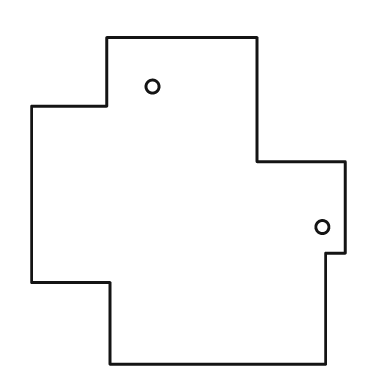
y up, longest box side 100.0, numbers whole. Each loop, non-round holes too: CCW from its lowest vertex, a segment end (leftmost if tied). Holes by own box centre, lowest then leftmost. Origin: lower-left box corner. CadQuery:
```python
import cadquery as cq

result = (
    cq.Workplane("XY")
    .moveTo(24.0, 0.0)
    .lineTo(90.0, 0.0)
    .lineTo(90.0, 34.0)
    .lineTo(96.0, 34.0)
    .lineTo(96.0, 62.0)
    .lineTo(69.0, 62.0)
    .lineTo(69.0, 100.0)
    .lineTo(23.0, 100.0)
    .lineTo(23.0, 79.0)
    .lineTo(0.0, 79.0)
    .lineTo(0.0, 25.0)
    .lineTo(24.0, 25.0)
    .close()
    .moveTo(89.0, 42.0)
    .circle(2.0)
    .moveTo(37.0, 85.0)
    .circle(2.0)
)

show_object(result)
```